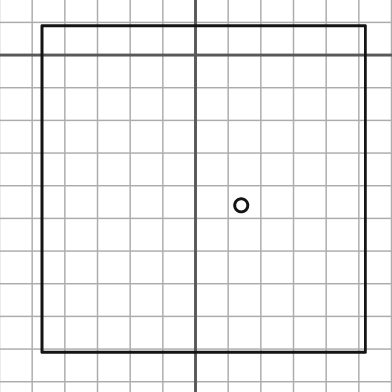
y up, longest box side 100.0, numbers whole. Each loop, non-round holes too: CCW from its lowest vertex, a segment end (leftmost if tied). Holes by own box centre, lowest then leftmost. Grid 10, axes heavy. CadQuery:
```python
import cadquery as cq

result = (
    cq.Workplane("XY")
    .moveTo(-47.0, -91.0)
    .lineTo(52.0, -91.0)
    .lineTo(52.0, 9.0)
    .lineTo(-47.0, 9.0)
    .close()
    .moveTo(14.0, -46.0)
    .circle(2.0)
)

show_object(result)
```